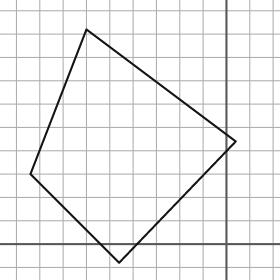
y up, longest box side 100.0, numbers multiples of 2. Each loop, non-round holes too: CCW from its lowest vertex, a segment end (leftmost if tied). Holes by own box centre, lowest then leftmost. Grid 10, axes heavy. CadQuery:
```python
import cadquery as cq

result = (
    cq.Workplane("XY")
    .moveTo(-46.0, -8.0)
    .lineTo(4.0, 44.0)
    .lineTo(-60.0, 92.0)
    .lineTo(-84.0, 30.0)
    .close()
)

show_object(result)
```